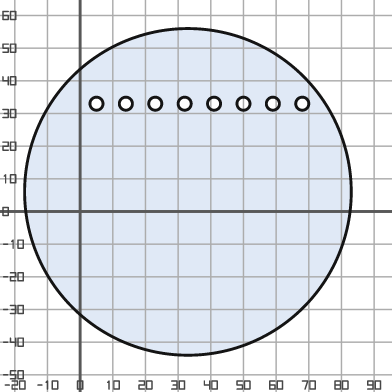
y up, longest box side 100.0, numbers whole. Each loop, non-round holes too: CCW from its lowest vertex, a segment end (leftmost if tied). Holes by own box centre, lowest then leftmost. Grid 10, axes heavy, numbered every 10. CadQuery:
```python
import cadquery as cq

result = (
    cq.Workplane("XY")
    .moveTo(33.0, 6.0)
    .circle(50.0)
    .moveTo(5.0, 33.0)
    .circle(2.0)
    .moveTo(14.0, 33.0)
    .circle(2.0)
    .moveTo(23.0, 33.0)
    .circle(2.0)
    .moveTo(32.0, 33.0)
    .circle(2.0)
    .moveTo(41.0, 33.0)
    .circle(2.0)
    .moveTo(50.0, 33.0)
    .circle(2.0)
    .moveTo(59.0, 33.0)
    .circle(2.0)
    .moveTo(68.0, 33.0)
    .circle(2.0)
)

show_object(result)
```